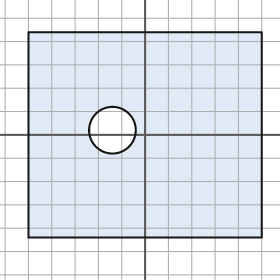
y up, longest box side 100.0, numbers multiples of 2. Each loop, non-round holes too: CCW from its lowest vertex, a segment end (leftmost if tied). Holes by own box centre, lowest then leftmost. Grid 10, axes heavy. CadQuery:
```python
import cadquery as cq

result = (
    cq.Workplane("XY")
    .moveTo(-50.0, -44.0)
    .lineTo(50.0, -44.0)
    .lineTo(50.0, 44.0)
    .lineTo(-50.0, 44.0)
    .close()
    .moveTo(-14.0, 2.0)
    .circle(10.0)
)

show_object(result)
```